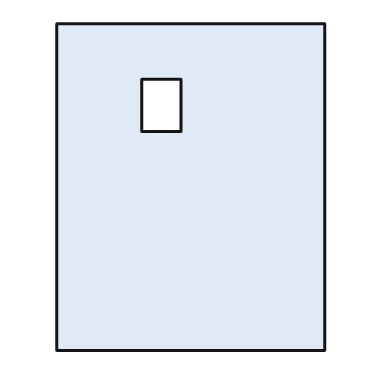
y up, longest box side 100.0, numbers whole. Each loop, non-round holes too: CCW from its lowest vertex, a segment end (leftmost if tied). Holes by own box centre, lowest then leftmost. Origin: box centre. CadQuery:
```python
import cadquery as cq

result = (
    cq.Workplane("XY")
    .moveTo(-41.0, -50.0)
    .lineTo(41.0, -50.0)
    .lineTo(41.0, 50.0)
    .lineTo(-41.0, 50.0)
    .close()
    .moveTo(-15.0, 17.0)
    .lineTo(-3.0, 17.0)
    .lineTo(-3.0, 33.0)
    .lineTo(-15.0, 33.0)
    .close()
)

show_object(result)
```